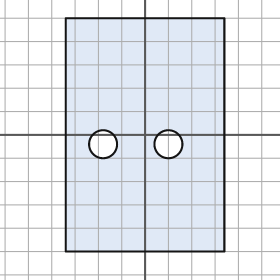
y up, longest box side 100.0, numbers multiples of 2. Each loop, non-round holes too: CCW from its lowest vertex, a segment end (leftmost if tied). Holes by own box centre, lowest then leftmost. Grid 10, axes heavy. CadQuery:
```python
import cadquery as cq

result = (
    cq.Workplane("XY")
    .moveTo(-34.0, -50.0)
    .lineTo(34.0, -50.0)
    .lineTo(34.0, 50.0)
    .lineTo(-34.0, 50.0)
    .close()
    .moveTo(-18.0, -4.0)
    .circle(6.0)
    .moveTo(10.0, -4.0)
    .circle(6.0)
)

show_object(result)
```